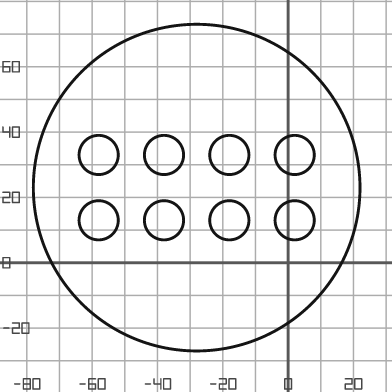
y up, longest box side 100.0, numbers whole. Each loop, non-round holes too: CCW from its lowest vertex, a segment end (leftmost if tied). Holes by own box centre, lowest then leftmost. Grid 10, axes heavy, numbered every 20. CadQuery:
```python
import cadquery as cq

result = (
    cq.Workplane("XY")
    .moveTo(-28.0, 23.0)
    .circle(50.0)
    .moveTo(-58.0, 13.0)
    .circle(6.0)
    .moveTo(-38.0, 13.0)
    .circle(6.0)
    .moveTo(-18.0, 13.0)
    .circle(6.0)
    .moveTo(2.0, 13.0)
    .circle(6.0)
    .moveTo(-58.0, 33.0)
    .circle(6.0)
    .moveTo(-38.0, 33.0)
    .circle(6.0)
    .moveTo(-18.0, 33.0)
    .circle(6.0)
    .moveTo(2.0, 33.0)
    .circle(6.0)
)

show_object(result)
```